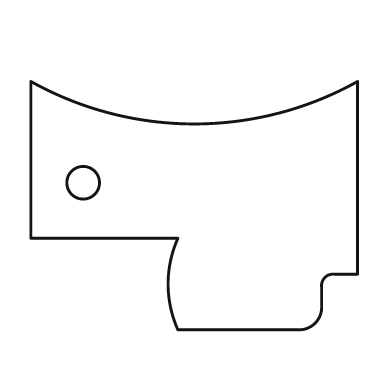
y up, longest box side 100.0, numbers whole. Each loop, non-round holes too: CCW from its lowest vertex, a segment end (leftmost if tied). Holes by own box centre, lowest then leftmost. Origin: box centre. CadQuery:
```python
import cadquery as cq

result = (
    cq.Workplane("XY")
    .moveTo(-5.0, -38.0)
    .lineTo(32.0, -38.0)
    .threePointArc((37.0, -36.0), (39.0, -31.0))
    .lineTo(39.0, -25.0)
    .threePointArc((40.0, -22.0), (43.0, -21.0))
    .lineTo(50.0, -21.0)
    .lineTo(50.0, 38.0)
    .threePointArc((0.0, 25.0), (-50.0, 38.0))
    .lineTo(-50.0, -10.0)
    .lineTo(-5.0, -10.0)
    .threePointArc((-8.0, -24.0), (-5.0, -38.0))
    .close()
    .moveTo(-34.0, 7.0)
    .circle(5.0)
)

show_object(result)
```